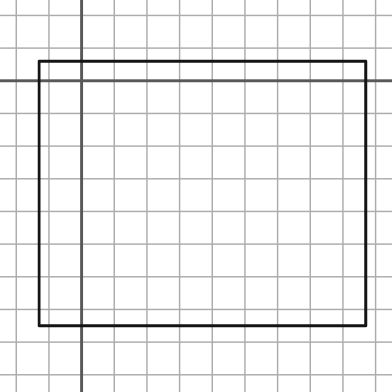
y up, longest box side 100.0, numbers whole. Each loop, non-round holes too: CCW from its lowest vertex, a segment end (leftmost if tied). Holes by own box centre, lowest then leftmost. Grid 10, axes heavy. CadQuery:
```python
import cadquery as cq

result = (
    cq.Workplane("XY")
    .moveTo(-13.0, -75.0)
    .lineTo(87.0, -75.0)
    .lineTo(87.0, 6.0)
    .lineTo(-13.0, 6.0)
    .close()
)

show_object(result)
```